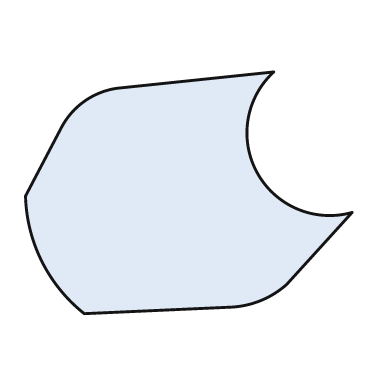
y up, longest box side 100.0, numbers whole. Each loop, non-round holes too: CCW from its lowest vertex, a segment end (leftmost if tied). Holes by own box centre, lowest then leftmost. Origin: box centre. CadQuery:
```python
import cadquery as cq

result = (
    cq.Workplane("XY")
    .moveTo(-32.0, -37.0)
    .lineTo(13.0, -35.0)
    .threePointArc((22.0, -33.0), (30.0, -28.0))
    .lineTo(50.0, -6.0)
    .threePointArc((21.0, 6.0), (26.0, 37.0))
    .lineTo(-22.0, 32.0)
    .threePointArc((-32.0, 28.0), (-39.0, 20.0))
    .lineTo(-50.0, -1.0)
    .threePointArc((-45.0, -21.0), (-32.0, -37.0))
    .close()
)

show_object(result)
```